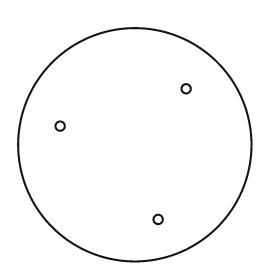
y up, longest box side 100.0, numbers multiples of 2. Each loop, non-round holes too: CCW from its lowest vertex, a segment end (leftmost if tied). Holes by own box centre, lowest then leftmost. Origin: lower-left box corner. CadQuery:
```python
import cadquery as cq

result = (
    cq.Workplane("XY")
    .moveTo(50.0, 50.0)
    .circle(50.0)
    .moveTo(60.0, 18.0)
    .circle(2.0)
    .moveTo(18.0, 58.0)
    .circle(2.0)
    .moveTo(72.0, 74.0)
    .circle(2.0)
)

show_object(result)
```